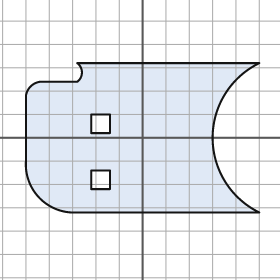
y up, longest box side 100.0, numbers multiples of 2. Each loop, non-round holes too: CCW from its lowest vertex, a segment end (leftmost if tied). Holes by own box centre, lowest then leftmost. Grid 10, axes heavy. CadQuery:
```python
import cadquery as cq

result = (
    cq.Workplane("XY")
    .moveTo(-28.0, -32.0)
    .lineTo(50.0, -32.0)
    .threePointArc((30.0, 0.0), (50.0, 32.0))
    .lineTo(-28.0, 32.0)
    .threePointArc((-26.0, 28.0), (-28.0, 24.0))
    .lineTo(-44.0, 24.0)
    .threePointArc((-48.0, 22.0), (-50.0, 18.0))
    .lineTo(-50.0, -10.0)
    .threePointArc((-44.0, -26.0), (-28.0, -32.0))
    .close()
    .moveTo(-22.0, -22.0)
    .lineTo(-14.0, -22.0)
    .lineTo(-14.0, -14.0)
    .lineTo(-22.0, -14.0)
    .close()
    .moveTo(-22.0, 2.0)
    .lineTo(-14.0, 2.0)
    .lineTo(-14.0, 10.0)
    .lineTo(-22.0, 10.0)
    .close()
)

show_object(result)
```